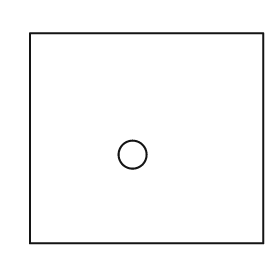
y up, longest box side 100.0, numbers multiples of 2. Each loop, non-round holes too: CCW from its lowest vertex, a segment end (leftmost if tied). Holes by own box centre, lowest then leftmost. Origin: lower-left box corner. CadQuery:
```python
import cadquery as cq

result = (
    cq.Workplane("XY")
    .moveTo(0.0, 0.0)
    .lineTo(100.0, 0.0)
    .lineTo(100.0, 90.0)
    .lineTo(0.0, 90.0)
    .close()
    .moveTo(44.0, 38.0)
    .circle(6.0)
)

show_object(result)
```